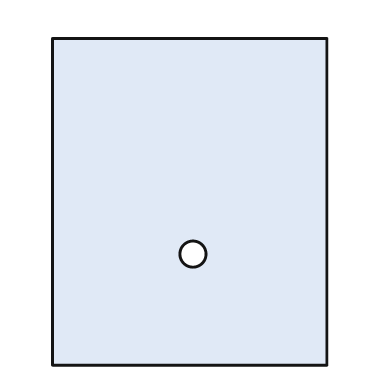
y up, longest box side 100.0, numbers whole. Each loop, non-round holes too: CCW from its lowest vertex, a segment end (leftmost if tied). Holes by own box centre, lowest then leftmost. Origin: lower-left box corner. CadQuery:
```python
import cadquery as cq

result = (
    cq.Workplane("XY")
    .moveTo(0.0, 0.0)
    .lineTo(84.0, 0.0)
    .lineTo(84.0, 100.0)
    .lineTo(0.0, 100.0)
    .close()
    .moveTo(43.0, 34.0)
    .circle(4.0)
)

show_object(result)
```